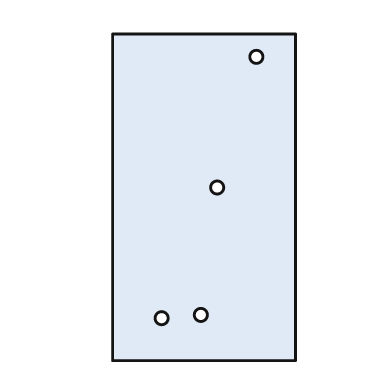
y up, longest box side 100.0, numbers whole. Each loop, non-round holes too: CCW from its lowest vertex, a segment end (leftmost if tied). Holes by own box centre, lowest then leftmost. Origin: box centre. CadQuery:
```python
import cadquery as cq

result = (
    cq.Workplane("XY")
    .moveTo(-28.0, -50.0)
    .lineTo(28.0, -50.0)
    .lineTo(28.0, 50.0)
    .lineTo(-28.0, 50.0)
    .close()
    .moveTo(-13.0, -37.0)
    .circle(2.0)
    .moveTo(-1.0, -36.0)
    .circle(2.0)
    .moveTo(4.0, 3.0)
    .circle(2.0)
    .moveTo(16.0, 43.0)
    .circle(2.0)
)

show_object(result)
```